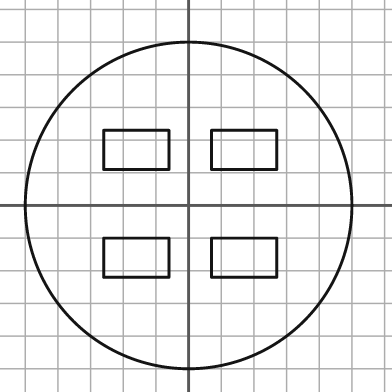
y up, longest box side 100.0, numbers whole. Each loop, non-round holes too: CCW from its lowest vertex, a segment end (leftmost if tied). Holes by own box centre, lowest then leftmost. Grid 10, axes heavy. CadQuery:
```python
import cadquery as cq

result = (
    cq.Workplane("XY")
    .moveTo(0.0, 0.0)
    .circle(50.0)
    .moveTo(-26.0, -22.0)
    .lineTo(-6.0, -22.0)
    .lineTo(-6.0, -10.0)
    .lineTo(-26.0, -10.0)
    .close()
    .moveTo(7.0, -22.0)
    .lineTo(27.0, -22.0)
    .lineTo(27.0, -10.0)
    .lineTo(7.0, -10.0)
    .close()
    .moveTo(-26.0, 11.0)
    .lineTo(-6.0, 11.0)
    .lineTo(-6.0, 23.0)
    .lineTo(-26.0, 23.0)
    .close()
    .moveTo(7.0, 11.0)
    .lineTo(27.0, 11.0)
    .lineTo(27.0, 23.0)
    .lineTo(7.0, 23.0)
    .close()
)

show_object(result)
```